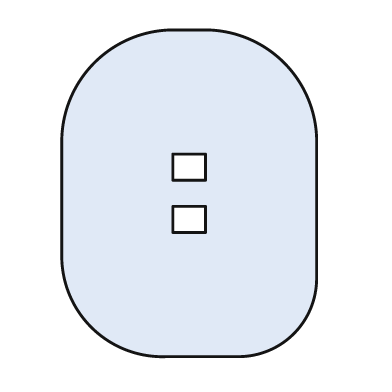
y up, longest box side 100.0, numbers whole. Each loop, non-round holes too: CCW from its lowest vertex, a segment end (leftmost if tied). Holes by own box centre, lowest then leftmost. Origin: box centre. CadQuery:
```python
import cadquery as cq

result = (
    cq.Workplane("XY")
    .moveTo(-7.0, -50.0)
    .lineTo(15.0, -50.0)
    .threePointArc((32.0, -43.0), (39.0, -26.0))
    .lineTo(39.0, 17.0)
    .threePointArc((29.0, 40.0), (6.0, 50.0))
    .lineTo(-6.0, 50.0)
    .threePointArc((-29.0, 40.0), (-39.0, 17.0))
    .lineTo(-39.0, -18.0)
    .threePointArc((-30.0, -41.0), (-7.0, -50.0))
    .close()
    .moveTo(-5.0, -12.0)
    .lineTo(5.0, -12.0)
    .lineTo(5.0, -4.0)
    .lineTo(-5.0, -4.0)
    .close()
    .moveTo(-5.0, 4.0)
    .lineTo(5.0, 4.0)
    .lineTo(5.0, 12.0)
    .lineTo(-5.0, 12.0)
    .close()
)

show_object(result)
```